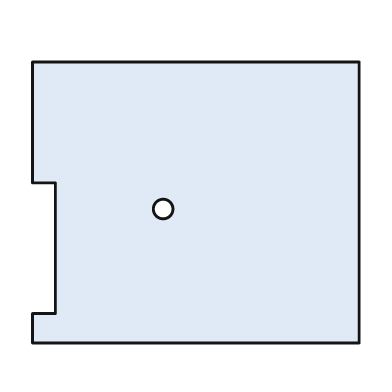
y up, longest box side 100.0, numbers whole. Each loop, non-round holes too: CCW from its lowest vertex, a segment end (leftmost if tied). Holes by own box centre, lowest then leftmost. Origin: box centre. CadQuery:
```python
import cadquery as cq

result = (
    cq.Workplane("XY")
    .moveTo(-50.0, -43.0)
    .lineTo(50.0, -43.0)
    .lineTo(50.0, 43.0)
    .lineTo(-50.0, 43.0)
    .lineTo(-50.0, 6.0)
    .lineTo(-43.0, 6.0)
    .lineTo(-43.0, -34.0)
    .lineTo(-50.0, -34.0)
    .close()
    .moveTo(-10.0, -2.0)
    .circle(3.0)
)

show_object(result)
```